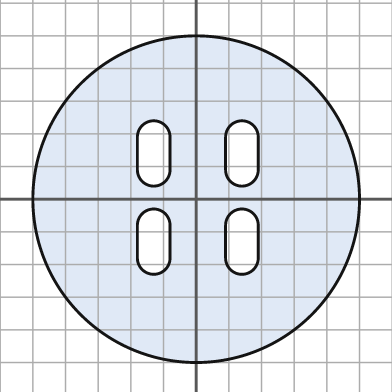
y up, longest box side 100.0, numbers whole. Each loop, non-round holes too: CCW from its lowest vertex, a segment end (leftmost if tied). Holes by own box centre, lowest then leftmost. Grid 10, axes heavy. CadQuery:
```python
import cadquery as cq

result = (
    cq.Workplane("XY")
    .moveTo(0.0, 0.0)
    .circle(50.0)
    .moveTo(-18.0, -18.0)
    .threePointArc((-13.0, -23.0), (-8.0, -18.0))
    .lineTo(-8.0, -8.0)
    .threePointArc((-13.0, -3.0), (-18.0, -8.0))
    .close()
    .moveTo(9.0, -18.0)
    .threePointArc((14.0, -23.0), (19.0, -18.0))
    .lineTo(19.0, -8.0)
    .threePointArc((14.0, -3.0), (9.0, -8.0))
    .close()
    .moveTo(-18.0, 9.0)
    .threePointArc((-13.0, 4.0), (-8.0, 9.0))
    .lineTo(-8.0, 19.0)
    .threePointArc((-13.0, 24.0), (-18.0, 19.0))
    .close()
    .moveTo(9.0, 9.0)
    .threePointArc((14.0, 4.0), (19.0, 9.0))
    .lineTo(19.0, 19.0)
    .threePointArc((14.0, 24.0), (9.0, 19.0))
    .close()
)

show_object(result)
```